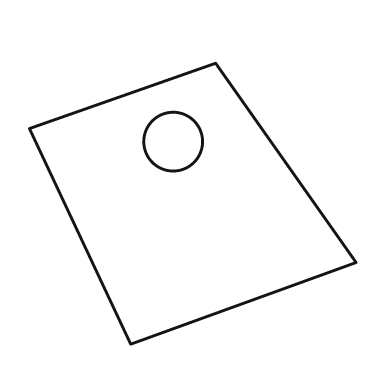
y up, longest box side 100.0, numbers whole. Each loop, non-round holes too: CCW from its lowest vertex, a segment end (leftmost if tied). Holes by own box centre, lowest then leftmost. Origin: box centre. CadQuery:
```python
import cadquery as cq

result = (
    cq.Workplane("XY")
    .moveTo(-19.0, -43.0)
    .lineTo(50.0, -18.0)
    .lineTo(7.0, 43.0)
    .lineTo(-50.0, 23.0)
    .close()
    .moveTo(-6.0, 19.0)
    .circle(9.0)
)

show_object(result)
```